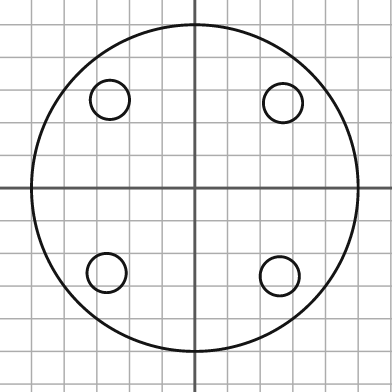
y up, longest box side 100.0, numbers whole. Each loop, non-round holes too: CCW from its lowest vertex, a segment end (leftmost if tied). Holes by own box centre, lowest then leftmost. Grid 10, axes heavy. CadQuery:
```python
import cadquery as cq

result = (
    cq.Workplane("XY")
    .moveTo(0.0, 0.0)
    .circle(50.0)
    .moveTo(26.0, -27.0)
    .circle(6.0)
    .moveTo(-27.0, -26.0)
    .circle(6.0)
    .moveTo(27.0, 26.0)
    .circle(6.0)
    .moveTo(-26.0, 27.0)
    .circle(6.0)
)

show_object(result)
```